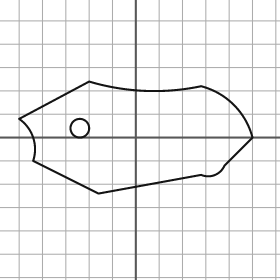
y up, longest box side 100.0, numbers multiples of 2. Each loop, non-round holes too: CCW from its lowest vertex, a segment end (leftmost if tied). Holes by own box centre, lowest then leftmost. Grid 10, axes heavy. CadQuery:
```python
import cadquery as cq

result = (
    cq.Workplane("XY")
    .moveTo(-16.0, -24.0)
    .lineTo(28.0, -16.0)
    .threePointArc((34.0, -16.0), (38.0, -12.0))
    .lineTo(50.0, 0.0)
    .threePointArc((42.0, 14.0), (28.0, 22.0))
    .threePointArc((4.0, 20.0), (-20.0, 24.0))
    .lineTo(-50.0, 8.0)
    .threePointArc((-44.0, 0.0), (-44.0, -10.0))
    .close()
    .moveTo(-24.0, 4.0)
    .circle(4.0)
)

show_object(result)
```